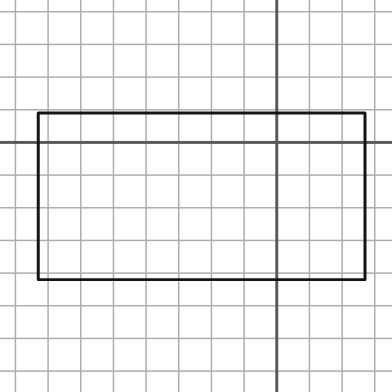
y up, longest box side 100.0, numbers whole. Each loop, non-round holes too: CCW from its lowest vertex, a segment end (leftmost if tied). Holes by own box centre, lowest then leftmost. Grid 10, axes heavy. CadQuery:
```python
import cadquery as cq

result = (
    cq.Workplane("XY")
    .moveTo(-73.0, -42.0)
    .lineTo(27.0, -42.0)
    .lineTo(27.0, 9.0)
    .lineTo(-73.0, 9.0)
    .close()
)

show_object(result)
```